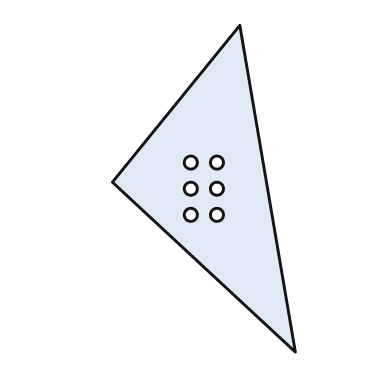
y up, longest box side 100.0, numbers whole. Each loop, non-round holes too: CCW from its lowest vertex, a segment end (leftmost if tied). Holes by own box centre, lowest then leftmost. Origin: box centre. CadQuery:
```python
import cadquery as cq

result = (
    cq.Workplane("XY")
    .moveTo(28.0, -50.0)
    .lineTo(11.0, 50.0)
    .lineTo(-28.0, 2.0)
    .close()
    .moveTo(-4.0, -8.0)
    .circle(2.0)
    .moveTo(4.0, -8.0)
    .circle(2.0)
    .moveTo(-4.0, 0.0)
    .circle(2.0)
    .moveTo(4.0, 0.0)
    .circle(2.0)
    .moveTo(-4.0, 8.0)
    .circle(2.0)
    .moveTo(4.0, 8.0)
    .circle(2.0)
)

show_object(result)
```